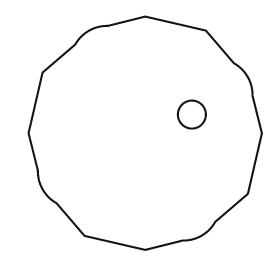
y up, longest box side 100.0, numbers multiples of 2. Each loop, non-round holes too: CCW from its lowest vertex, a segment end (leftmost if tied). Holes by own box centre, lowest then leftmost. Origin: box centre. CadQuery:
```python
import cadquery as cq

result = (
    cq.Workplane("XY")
    .moveTo(0.0, -50.0)
    .lineTo(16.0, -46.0)
    .threePointArc((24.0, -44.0), (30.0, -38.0))
    .lineTo(44.0, -26.0)
    .lineTo(50.0, 0.0)
    .lineTo(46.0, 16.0)
    .threePointArc((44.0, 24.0), (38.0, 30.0))
    .lineTo(26.0, 44.0)
    .lineTo(0.0, 50.0)
    .lineTo(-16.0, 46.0)
    .threePointArc((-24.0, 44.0), (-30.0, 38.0))
    .lineTo(-44.0, 26.0)
    .lineTo(-50.0, 0.0)
    .lineTo(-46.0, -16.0)
    .threePointArc((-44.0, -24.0), (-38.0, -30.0))
    .lineTo(-26.0, -44.0)
    .close()
    .moveTo(20.0, 8.0)
    .circle(6.0)
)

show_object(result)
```